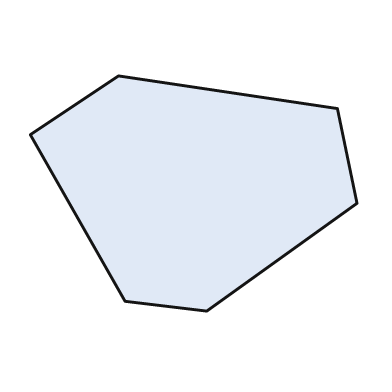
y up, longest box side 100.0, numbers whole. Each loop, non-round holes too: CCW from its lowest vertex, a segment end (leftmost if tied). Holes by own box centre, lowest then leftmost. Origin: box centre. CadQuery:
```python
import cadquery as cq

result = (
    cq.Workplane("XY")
    .moveTo(4.0, -36.0)
    .lineTo(50.0, -3.0)
    .lineTo(44.0, 26.0)
    .lineTo(-23.0, 36.0)
    .lineTo(-50.0, 18.0)
    .lineTo(-21.0, -33.0)
    .close()
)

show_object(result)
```